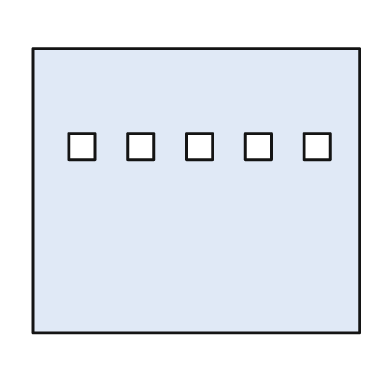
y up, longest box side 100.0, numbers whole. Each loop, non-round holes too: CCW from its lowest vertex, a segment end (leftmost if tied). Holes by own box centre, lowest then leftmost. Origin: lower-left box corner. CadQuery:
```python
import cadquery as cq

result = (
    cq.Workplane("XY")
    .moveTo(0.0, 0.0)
    .lineTo(100.0, 0.0)
    .lineTo(100.0, 87.0)
    .lineTo(0.0, 87.0)
    .close()
    .moveTo(11.0, 53.0)
    .lineTo(19.0, 53.0)
    .lineTo(19.0, 61.0)
    .lineTo(11.0, 61.0)
    .close()
    .moveTo(29.0, 53.0)
    .lineTo(37.0, 53.0)
    .lineTo(37.0, 61.0)
    .lineTo(29.0, 61.0)
    .close()
    .moveTo(47.0, 53.0)
    .lineTo(55.0, 53.0)
    .lineTo(55.0, 61.0)
    .lineTo(47.0, 61.0)
    .close()
    .moveTo(65.0, 53.0)
    .lineTo(73.0, 53.0)
    .lineTo(73.0, 61.0)
    .lineTo(65.0, 61.0)
    .close()
    .moveTo(83.0, 53.0)
    .lineTo(91.0, 53.0)
    .lineTo(91.0, 61.0)
    .lineTo(83.0, 61.0)
    .close()
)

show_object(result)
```